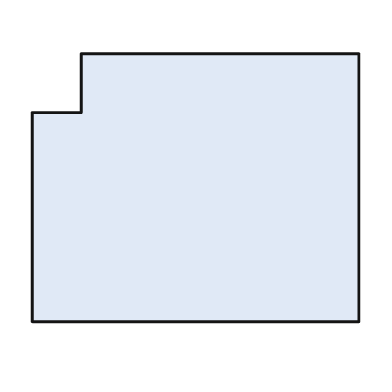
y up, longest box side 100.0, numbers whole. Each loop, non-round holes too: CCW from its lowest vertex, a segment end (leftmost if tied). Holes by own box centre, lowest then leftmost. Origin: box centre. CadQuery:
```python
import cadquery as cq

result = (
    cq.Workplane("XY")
    .moveTo(-50.0, -41.0)
    .lineTo(50.0, -41.0)
    .lineTo(50.0, 41.0)
    .lineTo(-35.0, 41.0)
    .lineTo(-35.0, 23.0)
    .lineTo(-50.0, 23.0)
    .close()
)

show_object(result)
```